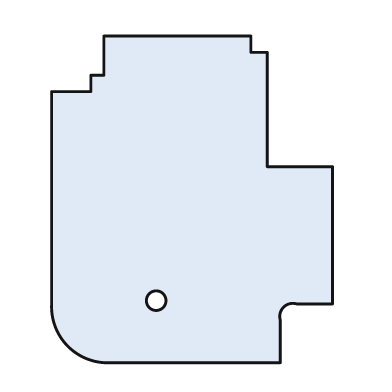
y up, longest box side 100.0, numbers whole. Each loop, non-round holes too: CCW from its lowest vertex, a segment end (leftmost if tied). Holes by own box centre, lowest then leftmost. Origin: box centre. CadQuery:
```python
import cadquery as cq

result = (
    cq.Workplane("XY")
    .moveTo(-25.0, -50.0)
    .lineTo(27.0, -50.0)
    .lineTo(27.0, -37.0)
    .threePointArc((28.0, -33.0), (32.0, -32.0))
    .lineTo(43.0, -32.0)
    .lineTo(43.0, 10.0)
    .lineTo(23.0, 10.0)
    .lineTo(23.0, 45.0)
    .lineTo(18.0, 45.0)
    .lineTo(18.0, 50.0)
    .lineTo(-27.0, 50.0)
    .lineTo(-27.0, 38.0)
    .lineTo(-31.0, 38.0)
    .lineTo(-31.0, 33.0)
    .lineTo(-43.0, 33.0)
    .lineTo(-43.0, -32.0)
    .threePointArc((-38.0, -45.0), (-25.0, -50.0))
    .close()
    .moveTo(-11.0, -31.0)
    .circle(3.0)
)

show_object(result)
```